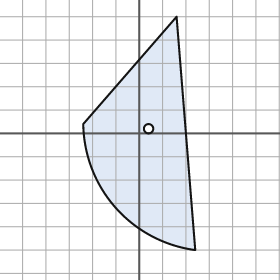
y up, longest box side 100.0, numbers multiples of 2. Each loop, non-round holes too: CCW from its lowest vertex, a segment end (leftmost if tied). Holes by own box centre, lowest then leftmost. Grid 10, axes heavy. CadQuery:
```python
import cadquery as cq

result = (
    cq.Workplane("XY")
    .moveTo(24.0, -50.0)
    .lineTo(16.0, 50.0)
    .lineTo(-24.0, 4.0)
    .threePointArc((-10.0, -32.0), (24.0, -50.0))
    .close()
    .moveTo(4.0, 2.0)
    .circle(2.0)
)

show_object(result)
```